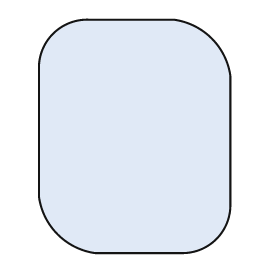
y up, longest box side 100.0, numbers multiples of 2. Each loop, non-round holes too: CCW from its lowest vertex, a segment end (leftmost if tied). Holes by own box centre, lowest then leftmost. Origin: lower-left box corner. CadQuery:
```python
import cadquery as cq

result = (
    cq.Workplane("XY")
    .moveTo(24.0, 0.0)
    .lineTo(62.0, 0.0)
    .threePointArc((76.0, 6.0), (82.0, 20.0))
    .lineTo(82.0, 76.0)
    .threePointArc((74.0, 92.0), (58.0, 100.0))
    .lineTo(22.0, 100.0)
    .threePointArc((6.0, 94.0), (0.0, 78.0))
    .lineTo(0.0, 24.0)
    .threePointArc((8.0, 8.0), (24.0, 0.0))
    .close()
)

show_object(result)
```